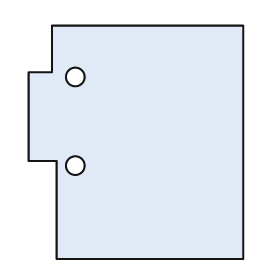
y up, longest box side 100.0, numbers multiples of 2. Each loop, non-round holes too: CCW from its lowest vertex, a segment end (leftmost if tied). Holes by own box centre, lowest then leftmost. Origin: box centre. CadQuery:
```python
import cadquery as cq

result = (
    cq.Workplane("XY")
    .moveTo(-34.0, -50.0)
    .lineTo(46.0, -50.0)
    .lineTo(46.0, 50.0)
    .lineTo(-36.0, 50.0)
    .lineTo(-36.0, 30.0)
    .lineTo(-46.0, 30.0)
    .lineTo(-46.0, -8.0)
    .lineTo(-34.0, -8.0)
    .close()
    .moveTo(-26.0, -10.0)
    .circle(4.0)
    .moveTo(-26.0, 28.0)
    .circle(4.0)
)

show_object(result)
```